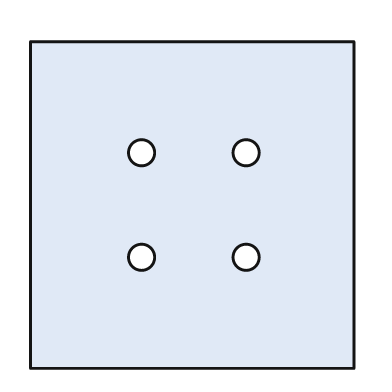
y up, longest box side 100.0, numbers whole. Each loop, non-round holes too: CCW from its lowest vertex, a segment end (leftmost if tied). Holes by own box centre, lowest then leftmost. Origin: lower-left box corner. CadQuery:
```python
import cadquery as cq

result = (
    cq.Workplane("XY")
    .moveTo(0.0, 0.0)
    .lineTo(99.0, 0.0)
    .lineTo(99.0, 100.0)
    .lineTo(0.0, 100.0)
    .close()
    .moveTo(34.0, 34.0)
    .circle(4.0)
    .moveTo(66.0, 34.0)
    .circle(4.0)
    .moveTo(34.0, 66.0)
    .circle(4.0)
    .moveTo(66.0, 66.0)
    .circle(4.0)
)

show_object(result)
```